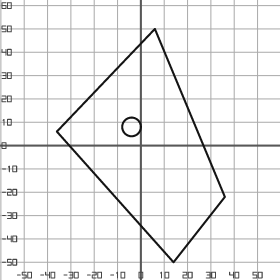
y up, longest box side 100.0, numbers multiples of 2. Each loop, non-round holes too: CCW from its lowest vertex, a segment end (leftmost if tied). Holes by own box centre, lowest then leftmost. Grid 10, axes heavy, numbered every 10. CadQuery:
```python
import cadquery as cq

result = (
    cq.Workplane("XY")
    .moveTo(14.0, -50.0)
    .lineTo(36.0, -22.0)
    .lineTo(6.0, 50.0)
    .lineTo(-36.0, 6.0)
    .close()
    .moveTo(-4.0, 8.0)
    .circle(4.0)
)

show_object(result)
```